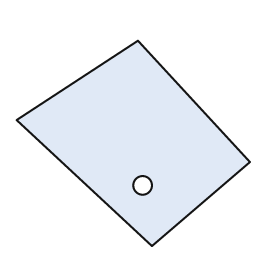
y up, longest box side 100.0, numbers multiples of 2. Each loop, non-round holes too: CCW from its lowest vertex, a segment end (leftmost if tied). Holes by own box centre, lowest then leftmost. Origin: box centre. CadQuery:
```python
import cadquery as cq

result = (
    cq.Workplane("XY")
    .moveTo(8.0, -44.0)
    .lineTo(50.0, -8.0)
    .lineTo(2.0, 44.0)
    .lineTo(-50.0, 10.0)
    .close()
    .moveTo(4.0, -18.0)
    .circle(4.0)
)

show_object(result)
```